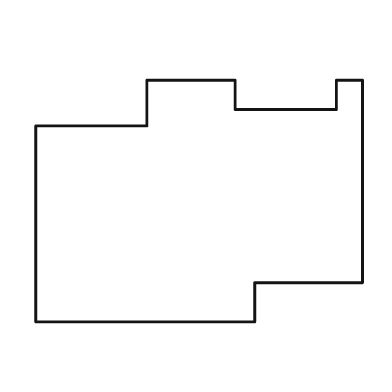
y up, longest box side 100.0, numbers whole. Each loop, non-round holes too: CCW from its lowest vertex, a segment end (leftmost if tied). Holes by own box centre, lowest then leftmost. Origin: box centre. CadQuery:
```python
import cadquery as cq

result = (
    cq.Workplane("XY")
    .moveTo(-50.0, -37.0)
    .lineTo(17.0, -37.0)
    .lineTo(17.0, -25.0)
    .lineTo(50.0, -25.0)
    .lineTo(50.0, 37.0)
    .lineTo(42.0, 37.0)
    .lineTo(42.0, 28.0)
    .lineTo(11.0, 28.0)
    .lineTo(11.0, 37.0)
    .lineTo(-16.0, 37.0)
    .lineTo(-16.0, 23.0)
    .lineTo(-50.0, 23.0)
    .close()
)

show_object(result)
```